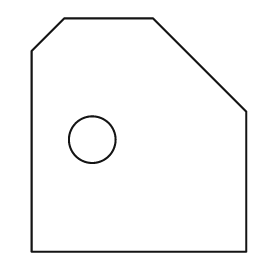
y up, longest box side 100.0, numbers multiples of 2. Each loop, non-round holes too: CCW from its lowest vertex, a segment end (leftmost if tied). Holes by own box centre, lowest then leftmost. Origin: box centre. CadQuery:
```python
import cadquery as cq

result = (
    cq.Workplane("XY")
    .moveTo(-46.0, -50.0)
    .lineTo(46.0, -50.0)
    .lineTo(46.0, 10.0)
    .lineTo(6.0, 50.0)
    .lineTo(-32.0, 50.0)
    .lineTo(-46.0, 36.0)
    .close()
    .moveTo(-20.0, -2.0)
    .circle(10.0)
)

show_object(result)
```